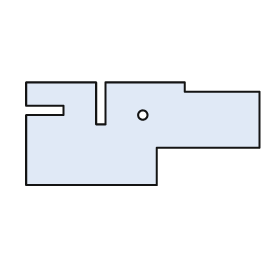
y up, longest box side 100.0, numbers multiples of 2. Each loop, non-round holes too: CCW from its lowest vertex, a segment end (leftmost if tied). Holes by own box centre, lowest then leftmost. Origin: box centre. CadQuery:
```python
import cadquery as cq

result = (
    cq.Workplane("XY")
    .moveTo(-50.0, -22.0)
    .lineTo(6.0, -22.0)
    .lineTo(6.0, -6.0)
    .lineTo(50.0, -6.0)
    .lineTo(50.0, 18.0)
    .lineTo(18.0, 18.0)
    .lineTo(18.0, 22.0)
    .lineTo(-16.0, 22.0)
    .lineTo(-16.0, 4.0)
    .lineTo(-20.0, 4.0)
    .lineTo(-20.0, 22.0)
    .lineTo(-50.0, 22.0)
    .lineTo(-50.0, 12.0)
    .lineTo(-34.0, 12.0)
    .lineTo(-34.0, 8.0)
    .lineTo(-50.0, 8.0)
    .close()
    .moveTo(0.0, 8.0)
    .circle(2.0)
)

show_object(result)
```